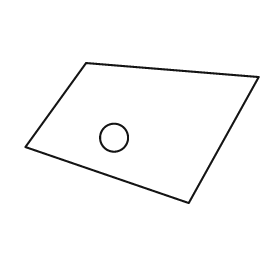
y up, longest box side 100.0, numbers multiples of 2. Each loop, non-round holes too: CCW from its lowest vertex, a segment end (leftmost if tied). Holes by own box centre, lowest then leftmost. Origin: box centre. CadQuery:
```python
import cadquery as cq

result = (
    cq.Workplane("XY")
    .moveTo(20.0, -30.0)
    .lineTo(50.0, 24.0)
    .lineTo(-24.0, 30.0)
    .lineTo(-50.0, -6.0)
    .close()
    .moveTo(-12.0, -2.0)
    .circle(6.0)
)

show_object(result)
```